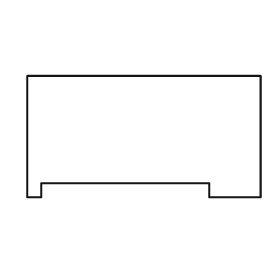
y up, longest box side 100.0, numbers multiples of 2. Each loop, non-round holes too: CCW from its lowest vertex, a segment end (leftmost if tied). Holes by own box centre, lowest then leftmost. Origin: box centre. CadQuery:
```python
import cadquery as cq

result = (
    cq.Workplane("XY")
    .moveTo(-50.0, -26.0)
    .lineTo(-44.0, -26.0)
    .lineTo(-44.0, -20.0)
    .lineTo(28.0, -20.0)
    .lineTo(28.0, -26.0)
    .lineTo(50.0, -26.0)
    .lineTo(50.0, 26.0)
    .lineTo(-50.0, 26.0)
    .close()
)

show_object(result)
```